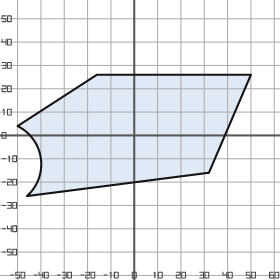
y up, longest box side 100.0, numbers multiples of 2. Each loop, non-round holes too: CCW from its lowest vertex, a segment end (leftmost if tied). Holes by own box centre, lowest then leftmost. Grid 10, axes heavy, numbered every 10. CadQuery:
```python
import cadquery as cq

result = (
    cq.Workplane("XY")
    .moveTo(-46.0, -26.0)
    .lineTo(32.0, -16.0)
    .lineTo(50.0, 26.0)
    .lineTo(-16.0, 26.0)
    .lineTo(-50.0, 4.0)
    .threePointArc((-40.0, -10.0), (-46.0, -26.0))
    .close()
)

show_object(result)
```